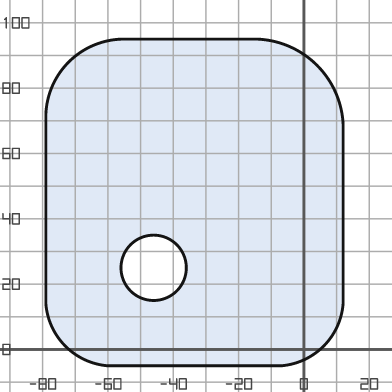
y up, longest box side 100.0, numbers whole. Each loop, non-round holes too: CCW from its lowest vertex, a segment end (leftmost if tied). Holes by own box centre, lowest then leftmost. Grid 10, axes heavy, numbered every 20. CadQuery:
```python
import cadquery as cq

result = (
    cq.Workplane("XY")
    .moveTo(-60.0, -5.0)
    .lineTo(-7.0, -5.0)
    .threePointArc((6.0, 1.0), (12.0, 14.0))
    .lineTo(12.0, 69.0)
    .threePointArc((4.0, 87.0), (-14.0, 95.0))
    .lineTo(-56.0, 95.0)
    .threePointArc((-72.0, 88.0), (-79.0, 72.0))
    .lineTo(-79.0, 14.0)
    .threePointArc((-73.0, 1.0), (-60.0, -5.0))
    .close()
    .moveTo(-46.0, 25.0)
    .circle(10.0)
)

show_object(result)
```